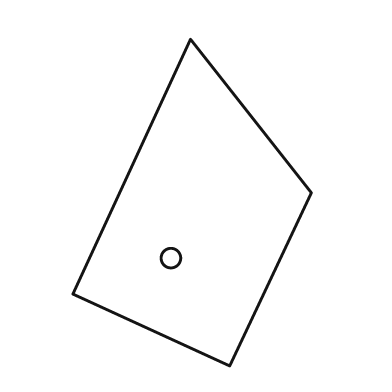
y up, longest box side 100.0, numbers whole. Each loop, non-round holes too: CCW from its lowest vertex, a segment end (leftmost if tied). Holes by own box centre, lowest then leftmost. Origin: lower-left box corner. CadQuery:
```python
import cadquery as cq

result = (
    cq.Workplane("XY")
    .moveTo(48.0, 0.0)
    .lineTo(73.0, 53.0)
    .lineTo(36.0, 100.0)
    .lineTo(0.0, 22.0)
    .close()
    .moveTo(30.0, 33.0)
    .circle(3.0)
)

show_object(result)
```